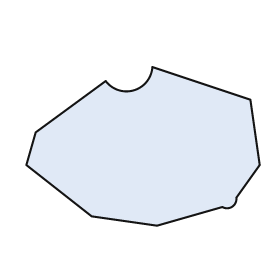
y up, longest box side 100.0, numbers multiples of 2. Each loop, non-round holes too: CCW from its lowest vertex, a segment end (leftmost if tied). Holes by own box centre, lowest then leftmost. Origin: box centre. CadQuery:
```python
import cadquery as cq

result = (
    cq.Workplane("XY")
    .moveTo(6.0, -34.0)
    .lineTo(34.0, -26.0)
    .threePointArc((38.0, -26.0), (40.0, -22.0))
    .lineTo(50.0, -8.0)
    .lineTo(46.0, 20.0)
    .lineTo(4.0, 34.0)
    .threePointArc((-4.0, 24.0), (-16.0, 28.0))
    .lineTo(-46.0, 6.0)
    .lineTo(-50.0, -8.0)
    .lineTo(-22.0, -30.0)
    .close()
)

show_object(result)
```